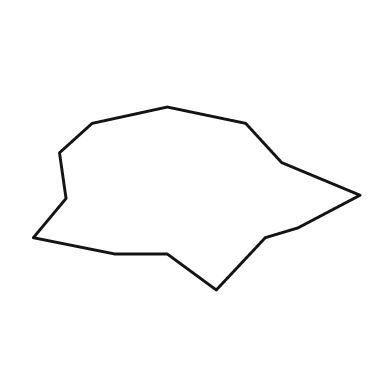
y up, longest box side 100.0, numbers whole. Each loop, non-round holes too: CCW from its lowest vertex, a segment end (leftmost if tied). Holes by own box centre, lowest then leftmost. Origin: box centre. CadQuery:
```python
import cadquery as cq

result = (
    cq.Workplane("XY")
    .moveTo(6.0, -28.0)
    .lineTo(21.0, -12.0)
    .lineTo(31.0, -9.0)
    .lineTo(50.0, 1.0)
    .lineTo(26.0, 11.0)
    .lineTo(15.0, 23.0)
    .lineTo(-9.0, 28.0)
    .lineTo(-32.0, 23.0)
    .lineTo(-42.0, 14.0)
    .lineTo(-40.0, 0.0)
    .lineTo(-50.0, -12.0)
    .lineTo(-25.0, -17.0)
    .lineTo(-9.0, -17.0)
    .close()
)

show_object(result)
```